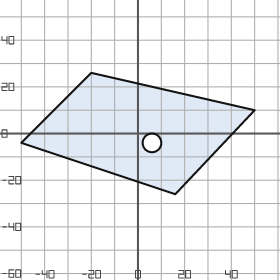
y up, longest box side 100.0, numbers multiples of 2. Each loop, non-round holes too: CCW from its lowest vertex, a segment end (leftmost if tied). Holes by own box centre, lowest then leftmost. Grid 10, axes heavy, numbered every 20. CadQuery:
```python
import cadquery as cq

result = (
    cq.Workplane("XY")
    .moveTo(16.0, -26.0)
    .lineTo(50.0, 10.0)
    .lineTo(-20.0, 26.0)
    .lineTo(-50.0, -4.0)
    .close()
    .moveTo(6.0, -4.0)
    .circle(4.0)
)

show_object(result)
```